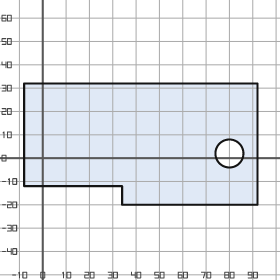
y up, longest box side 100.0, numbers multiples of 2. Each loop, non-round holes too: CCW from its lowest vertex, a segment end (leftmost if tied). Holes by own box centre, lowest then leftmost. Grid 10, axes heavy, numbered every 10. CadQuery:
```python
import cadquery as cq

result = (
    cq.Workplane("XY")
    .moveTo(34.0, -20.0)
    .lineTo(92.0, -20.0)
    .lineTo(92.0, 32.0)
    .lineTo(-8.0, 32.0)
    .lineTo(-8.0, -12.0)
    .lineTo(34.0, -12.0)
    .close()
    .moveTo(80.0, 2.0)
    .circle(6.0)
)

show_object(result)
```